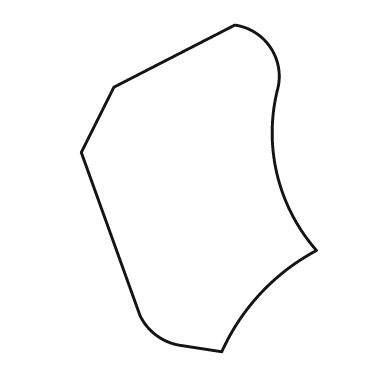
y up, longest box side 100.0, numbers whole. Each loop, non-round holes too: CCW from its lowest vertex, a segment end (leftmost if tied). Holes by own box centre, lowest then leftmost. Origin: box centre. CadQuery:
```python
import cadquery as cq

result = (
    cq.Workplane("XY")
    .moveTo(7.0, -50.0)
    .threePointArc((19.0, -32.0), (36.0, -19.0))
    .threePointArc((24.0, 4.0), (24.0, 30.0))
    .threePointArc((22.0, 43.0), (11.0, 50.0))
    .lineTo(-26.0, 31.0)
    .lineTo(-36.0, 11.0)
    .lineTo(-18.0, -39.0)
    .threePointArc((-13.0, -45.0), (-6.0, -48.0))
    .close()
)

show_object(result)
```